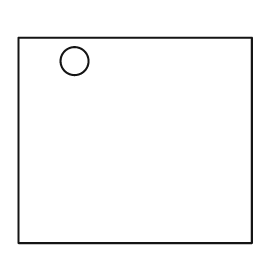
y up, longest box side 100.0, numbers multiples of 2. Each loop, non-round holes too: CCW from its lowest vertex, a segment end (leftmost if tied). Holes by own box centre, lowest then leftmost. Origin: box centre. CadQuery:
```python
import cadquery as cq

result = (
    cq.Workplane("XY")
    .moveTo(-50.0, -44.0)
    .lineTo(50.0, -44.0)
    .lineTo(50.0, 44.0)
    .lineTo(-50.0, 44.0)
    .close()
    .moveTo(-26.0, 34.0)
    .circle(6.0)
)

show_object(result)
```